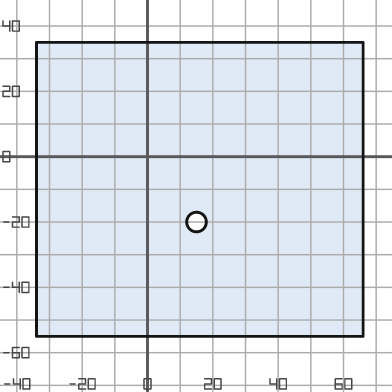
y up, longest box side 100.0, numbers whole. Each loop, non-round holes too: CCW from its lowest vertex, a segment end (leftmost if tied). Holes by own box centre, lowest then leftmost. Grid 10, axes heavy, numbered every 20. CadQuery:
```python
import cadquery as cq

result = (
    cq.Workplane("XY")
    .moveTo(-34.0, -55.0)
    .lineTo(66.0, -55.0)
    .lineTo(66.0, 35.0)
    .lineTo(-34.0, 35.0)
    .close()
    .moveTo(15.0, -20.0)
    .circle(3.0)
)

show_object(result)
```